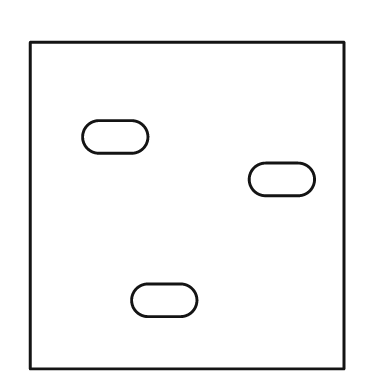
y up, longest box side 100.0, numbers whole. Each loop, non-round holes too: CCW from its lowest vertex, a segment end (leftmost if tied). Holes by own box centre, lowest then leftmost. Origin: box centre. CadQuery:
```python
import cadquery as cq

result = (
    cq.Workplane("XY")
    .moveTo(-48.0, -50.0)
    .lineTo(48.0, -50.0)
    .lineTo(48.0, 50.0)
    .lineTo(-48.0, 50.0)
    .close()
    .moveTo(-12.0, -34.0)
    .lineTo(-2.0, -34.0)
    .threePointArc((3.0, -29.0), (-2.0, -24.0))
    .lineTo(-12.0, -24.0)
    .threePointArc((-17.0, -29.0), (-12.0, -34.0))
    .close()
    .moveTo(24.0, 3.0)
    .lineTo(34.0, 3.0)
    .threePointArc((39.0, 8.0), (34.0, 13.0))
    .lineTo(24.0, 13.0)
    .threePointArc((19.0, 8.0), (24.0, 3.0))
    .close()
    .moveTo(-27.0, 16.0)
    .lineTo(-17.0, 16.0)
    .threePointArc((-12.0, 21.0), (-17.0, 26.0))
    .lineTo(-27.0, 26.0)
    .threePointArc((-32.0, 21.0), (-27.0, 16.0))
    .close()
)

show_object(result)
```